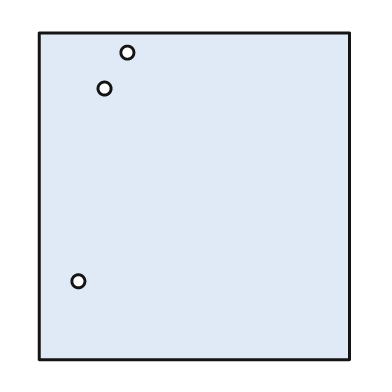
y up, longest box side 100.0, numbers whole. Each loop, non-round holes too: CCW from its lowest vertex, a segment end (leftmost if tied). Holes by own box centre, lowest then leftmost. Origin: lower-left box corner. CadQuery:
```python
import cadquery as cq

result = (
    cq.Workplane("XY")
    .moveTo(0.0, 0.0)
    .lineTo(95.0, 0.0)
    .lineTo(95.0, 100.0)
    .lineTo(0.0, 100.0)
    .close()
    .moveTo(12.0, 24.0)
    .circle(2.0)
    .moveTo(20.0, 83.0)
    .circle(2.0)
    .moveTo(27.0, 94.0)
    .circle(2.0)
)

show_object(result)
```